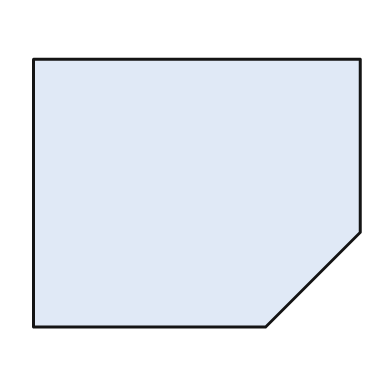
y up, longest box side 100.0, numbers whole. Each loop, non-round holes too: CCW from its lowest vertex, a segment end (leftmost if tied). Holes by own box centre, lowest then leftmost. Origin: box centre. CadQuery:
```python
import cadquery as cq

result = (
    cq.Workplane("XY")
    .moveTo(-50.0, -41.0)
    .lineTo(21.0, -41.0)
    .lineTo(50.0, -12.0)
    .lineTo(50.0, 41.0)
    .lineTo(-50.0, 41.0)
    .close()
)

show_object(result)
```